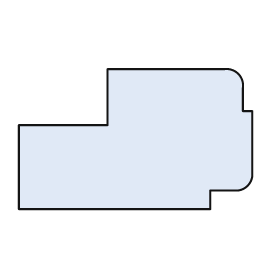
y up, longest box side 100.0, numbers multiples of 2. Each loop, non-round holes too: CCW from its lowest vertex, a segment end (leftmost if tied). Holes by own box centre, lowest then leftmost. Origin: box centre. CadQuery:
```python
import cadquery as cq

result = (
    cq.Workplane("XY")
    .moveTo(-50.0, -30.0)
    .lineTo(32.0, -30.0)
    .lineTo(32.0, -22.0)
    .lineTo(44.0, -22.0)
    .threePointArc((48.0, -20.0), (50.0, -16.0))
    .lineTo(50.0, 12.0)
    .lineTo(46.0, 12.0)
    .lineTo(46.0, 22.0)
    .threePointArc((44.0, 28.0), (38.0, 30.0))
    .lineTo(-12.0, 30.0)
    .lineTo(-12.0, 6.0)
    .lineTo(-50.0, 6.0)
    .close()
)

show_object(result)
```